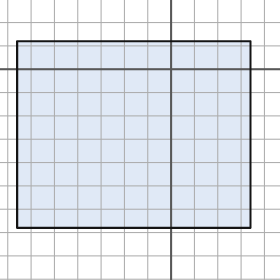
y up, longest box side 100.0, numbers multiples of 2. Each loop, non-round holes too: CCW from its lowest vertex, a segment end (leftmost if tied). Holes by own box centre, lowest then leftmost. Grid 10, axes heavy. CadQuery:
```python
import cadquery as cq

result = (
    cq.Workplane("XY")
    .moveTo(-66.0, -68.0)
    .lineTo(34.0, -68.0)
    .lineTo(34.0, 12.0)
    .lineTo(-66.0, 12.0)
    .close()
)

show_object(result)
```